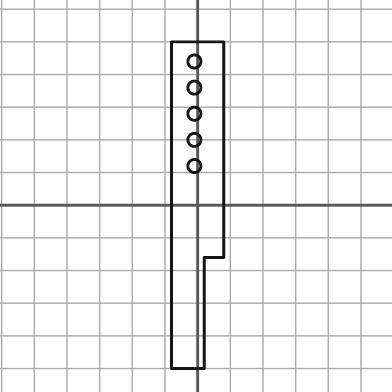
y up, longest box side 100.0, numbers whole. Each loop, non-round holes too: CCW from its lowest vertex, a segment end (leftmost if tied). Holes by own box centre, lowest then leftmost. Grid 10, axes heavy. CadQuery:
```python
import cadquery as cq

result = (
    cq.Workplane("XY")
    .moveTo(-8.0, -50.0)
    .lineTo(2.0, -50.0)
    .lineTo(2.0, -16.0)
    .lineTo(8.0, -16.0)
    .lineTo(8.0, 50.0)
    .lineTo(-8.0, 50.0)
    .close()
    .moveTo(-1.0, 12.0)
    .circle(2.0)
    .moveTo(-1.0, 20.0)
    .circle(2.0)
    .moveTo(-1.0, 28.0)
    .circle(2.0)
    .moveTo(-1.0, 36.0)
    .circle(2.0)
    .moveTo(-1.0, 44.0)
    .circle(2.0)
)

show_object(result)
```